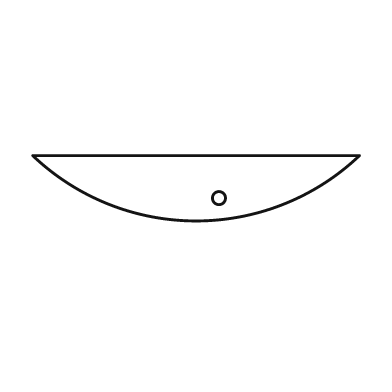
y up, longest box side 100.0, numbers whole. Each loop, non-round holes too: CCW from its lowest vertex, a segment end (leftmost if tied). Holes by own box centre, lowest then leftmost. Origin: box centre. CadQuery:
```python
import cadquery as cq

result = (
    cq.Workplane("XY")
    .moveTo(-50.0, 10.0)
    .threePointArc((0.0, -10.0), (50.0, 10.0))
    .close()
    .moveTo(7.0, -3.0)
    .circle(2.0)
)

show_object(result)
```